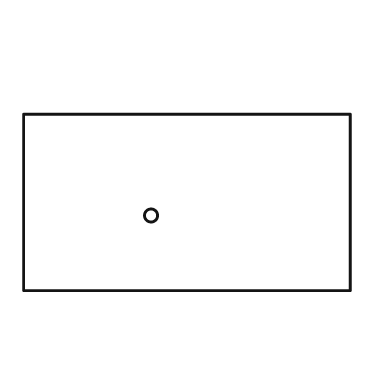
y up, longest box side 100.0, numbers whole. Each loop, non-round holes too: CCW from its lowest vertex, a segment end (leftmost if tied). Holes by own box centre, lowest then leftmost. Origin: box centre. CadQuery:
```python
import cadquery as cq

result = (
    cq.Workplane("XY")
    .moveTo(-50.0, -27.0)
    .lineTo(50.0, -27.0)
    .lineTo(50.0, 27.0)
    .lineTo(-50.0, 27.0)
    .close()
    .moveTo(-11.0, -4.0)
    .circle(2.0)
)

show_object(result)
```